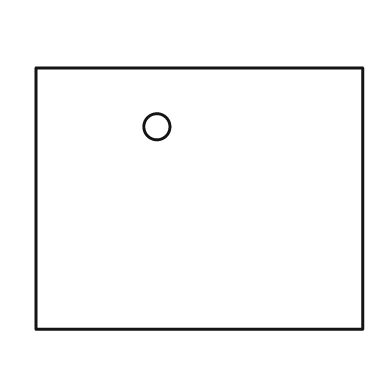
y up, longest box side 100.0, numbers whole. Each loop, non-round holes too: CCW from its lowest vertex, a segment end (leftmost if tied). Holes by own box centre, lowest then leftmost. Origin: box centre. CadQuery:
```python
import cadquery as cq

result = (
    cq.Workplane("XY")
    .moveTo(-50.0, -40.0)
    .lineTo(50.0, -40.0)
    .lineTo(50.0, 40.0)
    .lineTo(-50.0, 40.0)
    .close()
    .moveTo(-13.0, 22.0)
    .circle(4.0)
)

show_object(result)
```